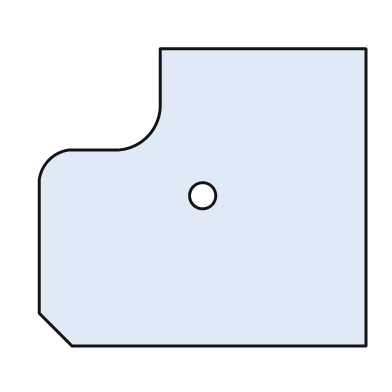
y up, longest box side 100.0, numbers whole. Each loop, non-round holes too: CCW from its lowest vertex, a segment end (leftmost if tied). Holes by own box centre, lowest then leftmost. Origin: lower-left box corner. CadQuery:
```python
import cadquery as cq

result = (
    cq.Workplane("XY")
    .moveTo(10.0, 0.0)
    .lineTo(100.0, 0.0)
    .lineTo(100.0, 91.0)
    .lineTo(37.0, 91.0)
    .lineTo(37.0, 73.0)
    .threePointArc((33.0, 64.0), (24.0, 60.0))
    .lineTo(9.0, 60.0)
    .threePointArc((3.0, 57.0), (0.0, 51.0))
    .lineTo(0.0, 10.0)
    .close()
    .moveTo(50.0, 46.0)
    .circle(4.0)
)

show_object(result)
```